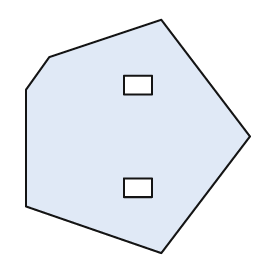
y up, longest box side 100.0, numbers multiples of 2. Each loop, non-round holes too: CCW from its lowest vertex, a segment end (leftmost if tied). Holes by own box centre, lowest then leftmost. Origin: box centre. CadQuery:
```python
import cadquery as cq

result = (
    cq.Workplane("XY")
    .moveTo(10.0, -50.0)
    .lineTo(48.0, 0.0)
    .lineTo(10.0, 50.0)
    .lineTo(-38.0, 34.0)
    .lineTo(-48.0, 20.0)
    .lineTo(-48.0, -30.0)
    .close()
    .moveTo(-6.0, -26.0)
    .lineTo(6.0, -26.0)
    .lineTo(6.0, -18.0)
    .lineTo(-6.0, -18.0)
    .close()
    .moveTo(-6.0, 18.0)
    .lineTo(6.0, 18.0)
    .lineTo(6.0, 26.0)
    .lineTo(-6.0, 26.0)
    .close()
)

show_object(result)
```